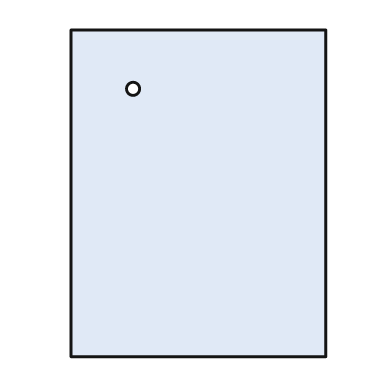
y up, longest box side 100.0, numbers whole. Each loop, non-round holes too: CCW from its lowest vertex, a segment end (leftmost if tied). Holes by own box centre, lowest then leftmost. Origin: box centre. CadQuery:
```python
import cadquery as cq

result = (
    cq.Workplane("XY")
    .moveTo(-39.0, -50.0)
    .lineTo(39.0, -50.0)
    .lineTo(39.0, 50.0)
    .lineTo(-39.0, 50.0)
    .close()
    .moveTo(-20.0, 32.0)
    .circle(2.0)
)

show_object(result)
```